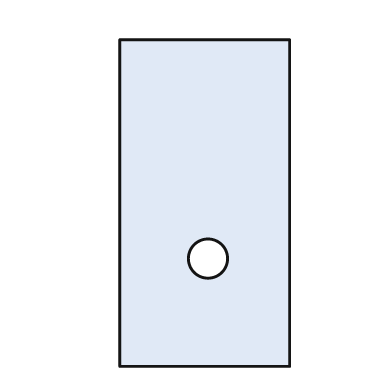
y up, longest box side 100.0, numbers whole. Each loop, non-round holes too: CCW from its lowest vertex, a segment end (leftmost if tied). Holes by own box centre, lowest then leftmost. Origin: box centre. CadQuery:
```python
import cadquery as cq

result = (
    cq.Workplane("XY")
    .moveTo(-26.0, -50.0)
    .lineTo(26.0, -50.0)
    .lineTo(26.0, 50.0)
    .lineTo(-26.0, 50.0)
    .close()
    .moveTo(1.0, -17.0)
    .circle(6.0)
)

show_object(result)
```